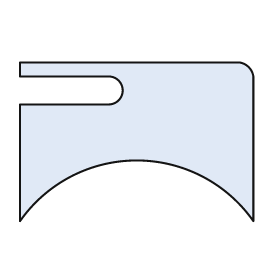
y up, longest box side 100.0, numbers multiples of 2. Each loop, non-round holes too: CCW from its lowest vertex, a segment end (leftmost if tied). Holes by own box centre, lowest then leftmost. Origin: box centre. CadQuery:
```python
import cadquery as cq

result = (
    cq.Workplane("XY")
    .moveTo(-50.0, -34.0)
    .threePointArc((0.0, -8.0), (50.0, -34.0))
    .lineTo(50.0, 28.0)
    .threePointArc((48.0, 32.0), (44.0, 34.0))
    .lineTo(-50.0, 34.0)
    .lineTo(-50.0, 28.0)
    .lineTo(-12.0, 28.0)
    .threePointArc((-6.0, 22.0), (-12.0, 16.0))
    .lineTo(-50.0, 16.0)
    .close()
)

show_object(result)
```